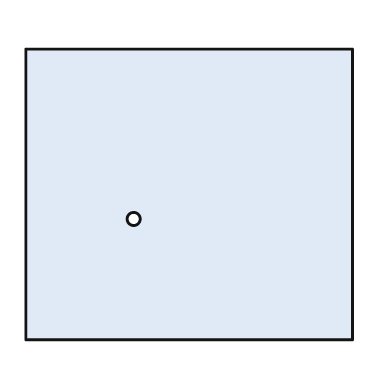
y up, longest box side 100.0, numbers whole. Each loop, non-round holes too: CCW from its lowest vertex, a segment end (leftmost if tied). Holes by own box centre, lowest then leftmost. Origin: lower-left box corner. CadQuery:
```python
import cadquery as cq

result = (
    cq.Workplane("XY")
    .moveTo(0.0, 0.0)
    .lineTo(100.0, 0.0)
    .lineTo(100.0, 89.0)
    .lineTo(0.0, 89.0)
    .close()
    .moveTo(33.0, 37.0)
    .circle(2.0)
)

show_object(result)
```